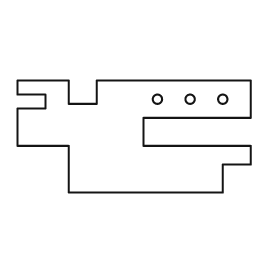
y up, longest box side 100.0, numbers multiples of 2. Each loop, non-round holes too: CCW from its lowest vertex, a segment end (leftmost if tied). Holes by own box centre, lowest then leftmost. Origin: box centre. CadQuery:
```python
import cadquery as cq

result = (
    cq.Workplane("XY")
    .moveTo(-28.0, -24.0)
    .lineTo(38.0, -24.0)
    .lineTo(38.0, -12.0)
    .lineTo(50.0, -12.0)
    .lineTo(50.0, -4.0)
    .lineTo(4.0, -4.0)
    .lineTo(4.0, 8.0)
    .lineTo(50.0, 8.0)
    .lineTo(50.0, 24.0)
    .lineTo(-16.0, 24.0)
    .lineTo(-16.0, 14.0)
    .lineTo(-28.0, 14.0)
    .lineTo(-28.0, 24.0)
    .lineTo(-50.0, 24.0)
    .lineTo(-50.0, 18.0)
    .lineTo(-38.0, 18.0)
    .lineTo(-38.0, 12.0)
    .lineTo(-50.0, 12.0)
    .lineTo(-50.0, -4.0)
    .lineTo(-28.0, -4.0)
    .close()
    .moveTo(10.0, 16.0)
    .circle(2.0)
    .moveTo(24.0, 16.0)
    .circle(2.0)
    .moveTo(38.0, 16.0)
    .circle(2.0)
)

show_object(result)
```